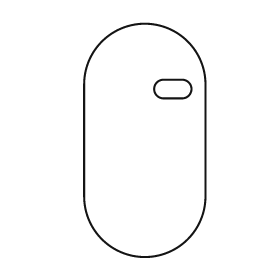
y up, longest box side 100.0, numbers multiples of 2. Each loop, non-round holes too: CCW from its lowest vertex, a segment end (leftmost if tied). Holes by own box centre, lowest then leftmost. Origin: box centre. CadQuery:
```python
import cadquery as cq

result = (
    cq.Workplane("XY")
    .moveTo(-26.0, -24.0)
    .threePointArc((0.0, -50.0), (26.0, -24.0))
    .lineTo(26.0, 24.0)
    .threePointArc((0.0, 50.0), (-26.0, 24.0))
    .close()
    .moveTo(8.0, 18.0)
    .lineTo(16.0, 18.0)
    .threePointArc((20.0, 22.0), (16.0, 26.0))
    .lineTo(8.0, 26.0)
    .threePointArc((4.0, 22.0), (8.0, 18.0))
    .close()
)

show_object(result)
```